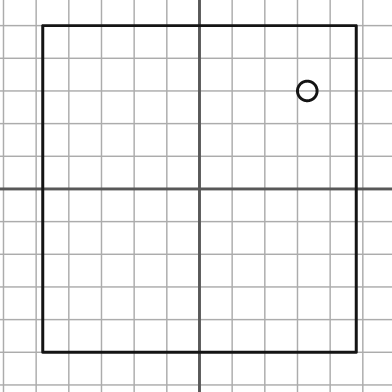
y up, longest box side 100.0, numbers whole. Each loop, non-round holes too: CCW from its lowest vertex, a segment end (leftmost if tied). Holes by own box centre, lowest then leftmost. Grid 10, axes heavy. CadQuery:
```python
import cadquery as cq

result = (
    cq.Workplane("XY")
    .moveTo(-48.0, -50.0)
    .lineTo(48.0, -50.0)
    .lineTo(48.0, 50.0)
    .lineTo(-48.0, 50.0)
    .close()
    .moveTo(33.0, 30.0)
    .circle(3.0)
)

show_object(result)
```